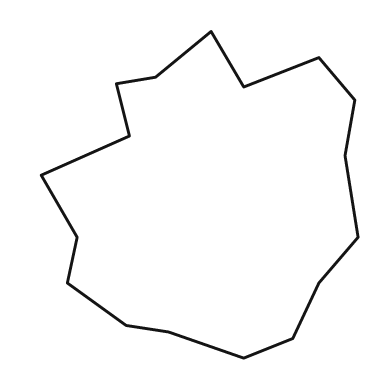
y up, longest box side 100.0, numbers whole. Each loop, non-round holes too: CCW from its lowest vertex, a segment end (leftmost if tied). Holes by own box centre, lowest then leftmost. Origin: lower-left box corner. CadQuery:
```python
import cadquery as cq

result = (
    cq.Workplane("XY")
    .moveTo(62.0, 0.0)
    .lineTo(77.0, 6.0)
    .lineTo(85.0, 23.0)
    .lineTo(97.0, 37.0)
    .lineTo(93.0, 62.0)
    .lineTo(96.0, 79.0)
    .lineTo(85.0, 92.0)
    .lineTo(62.0, 83.0)
    .lineTo(52.0, 100.0)
    .lineTo(35.0, 86.0)
    .lineTo(23.0, 84.0)
    .lineTo(27.0, 68.0)
    .lineTo(0.0, 56.0)
    .lineTo(11.0, 37.0)
    .lineTo(8.0, 23.0)
    .lineTo(26.0, 10.0)
    .lineTo(39.0, 8.0)
    .close()
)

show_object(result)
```